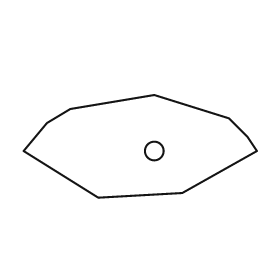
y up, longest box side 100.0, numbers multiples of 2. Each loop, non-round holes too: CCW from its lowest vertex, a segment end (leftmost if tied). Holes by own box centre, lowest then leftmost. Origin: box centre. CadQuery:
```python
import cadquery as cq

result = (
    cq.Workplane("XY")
    .moveTo(-18.0, -22.0)
    .lineTo(18.0, -20.0)
    .lineTo(50.0, -2.0)
    .lineTo(46.0, 4.0)
    .lineTo(38.0, 12.0)
    .lineTo(6.0, 22.0)
    .lineTo(-30.0, 16.0)
    .lineTo(-40.0, 10.0)
    .lineTo(-50.0, -2.0)
    .close()
    .moveTo(6.0, -2.0)
    .circle(4.0)
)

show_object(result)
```